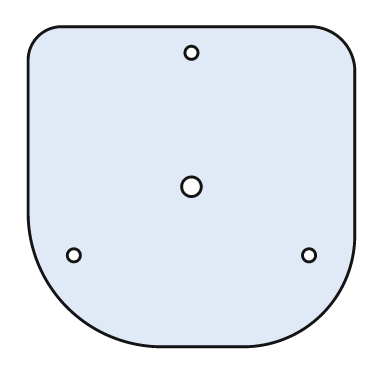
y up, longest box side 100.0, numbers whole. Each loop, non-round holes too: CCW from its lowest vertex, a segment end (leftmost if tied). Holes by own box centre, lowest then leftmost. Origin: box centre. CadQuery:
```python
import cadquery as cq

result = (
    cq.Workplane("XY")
    .moveTo(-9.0, -49.0)
    .lineTo(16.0, -49.0)
    .threePointArc((40.0, -39.0), (50.0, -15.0))
    .lineTo(50.0, 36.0)
    .threePointArc((46.0, 45.0), (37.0, 49.0))
    .lineTo(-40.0, 49.0)
    .threePointArc((-47.0, 46.0), (-50.0, 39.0))
    .lineTo(-50.0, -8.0)
    .threePointArc((-38.0, -37.0), (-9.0, -49.0))
    .close()
    .moveTo(-36.0, -21.0)
    .circle(2.0)
    .moveTo(36.0, -21.0)
    .circle(2.0)
    .moveTo(0.0, 0.0)
    .circle(3.0)
    .moveTo(0.0, 41.0)
    .circle(2.0)
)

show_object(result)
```